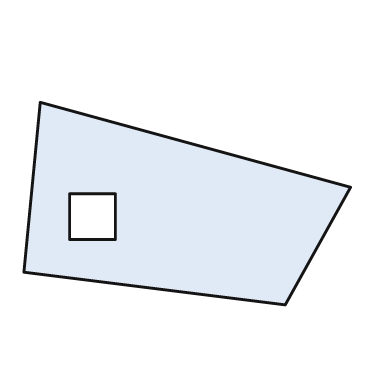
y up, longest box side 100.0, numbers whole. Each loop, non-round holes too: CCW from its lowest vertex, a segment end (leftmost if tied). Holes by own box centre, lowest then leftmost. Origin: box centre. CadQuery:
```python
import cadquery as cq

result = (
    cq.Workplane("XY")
    .moveTo(30.0, -31.0)
    .lineTo(50.0, 5.0)
    .lineTo(-45.0, 31.0)
    .lineTo(-50.0, -21.0)
    .close()
    .moveTo(-36.0, -11.0)
    .lineTo(-22.0, -11.0)
    .lineTo(-22.0, 3.0)
    .lineTo(-36.0, 3.0)
    .close()
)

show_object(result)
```